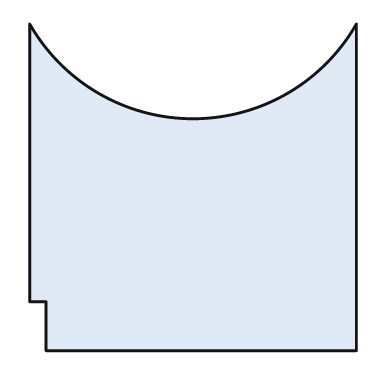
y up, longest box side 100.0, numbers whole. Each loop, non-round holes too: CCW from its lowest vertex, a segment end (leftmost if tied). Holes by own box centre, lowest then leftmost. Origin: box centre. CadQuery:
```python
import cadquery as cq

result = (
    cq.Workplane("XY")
    .moveTo(-45.0, -50.0)
    .lineTo(50.0, -50.0)
    .lineTo(50.0, 50.0)
    .threePointArc((0.0, 21.0), (-50.0, 50.0))
    .lineTo(-50.0, -35.0)
    .lineTo(-45.0, -35.0)
    .close()
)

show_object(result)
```